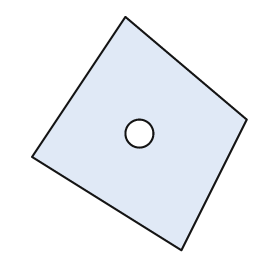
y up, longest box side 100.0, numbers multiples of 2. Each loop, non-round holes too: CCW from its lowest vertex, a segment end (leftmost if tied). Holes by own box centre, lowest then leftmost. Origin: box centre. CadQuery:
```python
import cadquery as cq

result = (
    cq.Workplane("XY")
    .moveTo(18.0, -50.0)
    .lineTo(46.0, 6.0)
    .lineTo(-6.0, 50.0)
    .lineTo(-46.0, -10.0)
    .close()
    .moveTo(0.0, 0.0)
    .circle(6.0)
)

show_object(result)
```